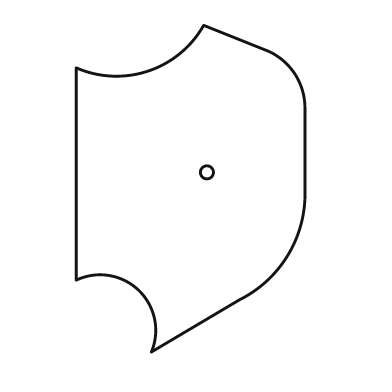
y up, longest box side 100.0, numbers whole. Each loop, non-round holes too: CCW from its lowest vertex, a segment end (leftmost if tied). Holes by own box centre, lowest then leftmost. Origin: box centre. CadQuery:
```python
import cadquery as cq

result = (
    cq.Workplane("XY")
    .moveTo(-12.0, -50.0)
    .lineTo(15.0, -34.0)
    .threePointArc((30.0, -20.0), (35.0, 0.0))
    .lineTo(35.0, 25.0)
    .threePointArc((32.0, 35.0), (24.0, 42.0))
    .lineTo(4.0, 50.0)
    .threePointArc((-13.0, 36.0), (-35.0, 37.0))
    .lineTo(-35.0, -28.0)
    .threePointArc((-16.0, -31.0), (-12.0, -50.0))
    .close()
    .moveTo(5.0, 5.0)
    .circle(2.0)
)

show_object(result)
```